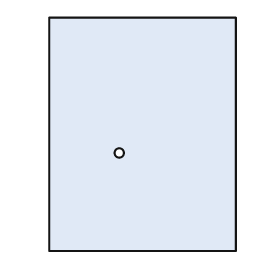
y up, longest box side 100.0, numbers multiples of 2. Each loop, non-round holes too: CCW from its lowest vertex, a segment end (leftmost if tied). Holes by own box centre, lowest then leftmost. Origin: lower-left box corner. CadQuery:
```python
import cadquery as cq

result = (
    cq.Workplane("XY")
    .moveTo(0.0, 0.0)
    .lineTo(80.0, 0.0)
    .lineTo(80.0, 100.0)
    .lineTo(0.0, 100.0)
    .close()
    .moveTo(30.0, 42.0)
    .circle(2.0)
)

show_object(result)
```